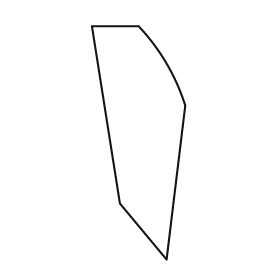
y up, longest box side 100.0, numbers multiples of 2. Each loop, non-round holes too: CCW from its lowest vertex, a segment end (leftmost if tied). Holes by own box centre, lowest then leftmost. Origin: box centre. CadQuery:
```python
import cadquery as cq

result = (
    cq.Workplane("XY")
    .moveTo(12.0, -50.0)
    .lineTo(20.0, 16.0)
    .threePointArc((12.0, 34.0), (0.0, 50.0))
    .lineTo(-20.0, 50.0)
    .lineTo(-8.0, -26.0)
    .close()
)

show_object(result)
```